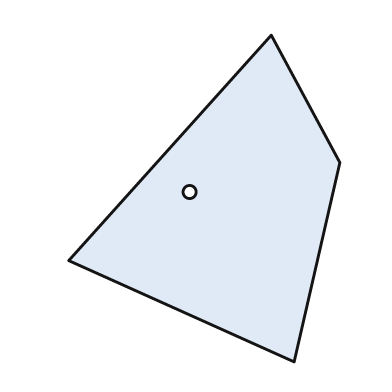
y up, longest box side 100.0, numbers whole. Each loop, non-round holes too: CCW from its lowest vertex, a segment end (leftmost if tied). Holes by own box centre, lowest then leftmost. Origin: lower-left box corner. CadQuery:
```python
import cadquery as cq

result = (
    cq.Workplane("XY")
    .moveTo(69.0, 0.0)
    .lineTo(83.0, 61.0)
    .lineTo(62.0, 100.0)
    .lineTo(0.0, 31.0)
    .close()
    .moveTo(37.0, 52.0)
    .circle(2.0)
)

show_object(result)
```